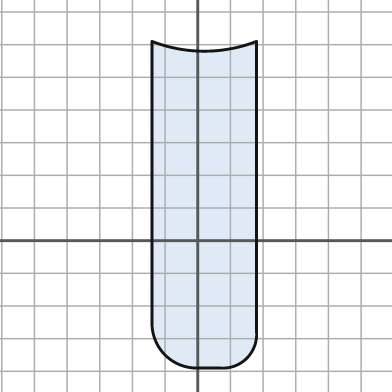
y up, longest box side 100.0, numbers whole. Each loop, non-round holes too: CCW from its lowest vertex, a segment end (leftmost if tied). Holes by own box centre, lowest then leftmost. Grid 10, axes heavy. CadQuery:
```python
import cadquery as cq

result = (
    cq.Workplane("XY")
    .moveTo(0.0, -39.0)
    .lineTo(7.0, -39.0)
    .threePointArc((15.0, -36.0), (18.0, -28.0))
    .lineTo(18.0, 61.0)
    .threePointArc((2.0, 58.0), (-14.0, 61.0))
    .lineTo(-14.0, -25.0)
    .threePointArc((-10.0, -35.0), (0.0, -39.0))
    .close()
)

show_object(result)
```